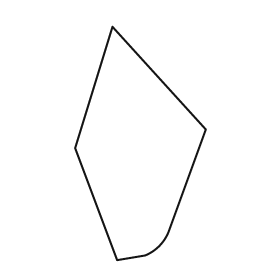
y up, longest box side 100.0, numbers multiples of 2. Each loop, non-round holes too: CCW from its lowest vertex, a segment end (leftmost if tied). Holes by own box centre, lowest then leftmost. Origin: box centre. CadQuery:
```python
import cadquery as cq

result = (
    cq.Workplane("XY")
    .moveTo(-10.0, -50.0)
    .lineTo(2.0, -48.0)
    .threePointArc((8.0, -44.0), (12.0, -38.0))
    .lineTo(28.0, 6.0)
    .lineTo(-12.0, 50.0)
    .lineTo(-28.0, -2.0)
    .close()
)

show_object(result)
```